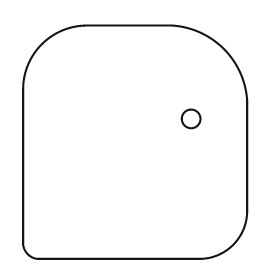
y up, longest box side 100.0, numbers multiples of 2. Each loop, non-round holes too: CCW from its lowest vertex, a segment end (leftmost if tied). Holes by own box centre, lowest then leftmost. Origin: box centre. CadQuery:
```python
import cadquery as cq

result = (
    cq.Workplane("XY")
    .moveTo(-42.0, -50.0)
    .lineTo(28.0, -50.0)
    .threePointArc((42.0, -44.0), (48.0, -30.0))
    .lineTo(48.0, 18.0)
    .threePointArc((38.0, 40.0), (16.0, 50.0))
    .lineTo(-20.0, 50.0)
    .threePointArc((-40.0, 42.0), (-48.0, 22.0))
    .lineTo(-48.0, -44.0)
    .threePointArc((-46.0, -48.0), (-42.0, -50.0))
    .close()
    .moveTo(24.0, 10.0)
    .circle(4.0)
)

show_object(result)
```